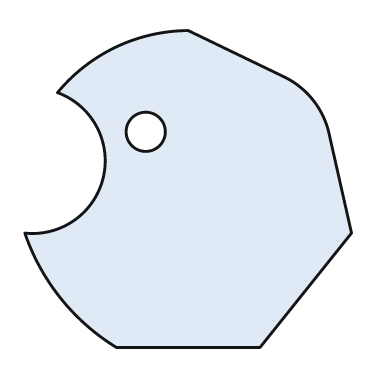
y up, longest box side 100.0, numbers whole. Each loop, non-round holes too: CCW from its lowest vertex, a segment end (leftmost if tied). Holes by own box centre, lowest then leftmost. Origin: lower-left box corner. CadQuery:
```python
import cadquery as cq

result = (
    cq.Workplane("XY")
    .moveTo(28.0, 0.0)
    .lineTo(72.0, 0.0)
    .lineTo(100.0, 35.0)
    .lineTo(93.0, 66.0)
    .threePointArc((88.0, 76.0), (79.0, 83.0))
    .lineTo(50.0, 97.0)
    .threePointArc((28.0, 92.0), (10.0, 78.0))
    .threePointArc((24.0, 52.0), (0.0, 35.0))
    .threePointArc((11.0, 15.0), (28.0, 0.0))
    .close()
    .moveTo(37.0, 66.0)
    .circle(6.0)
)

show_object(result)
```